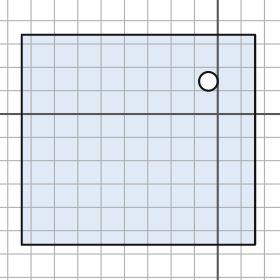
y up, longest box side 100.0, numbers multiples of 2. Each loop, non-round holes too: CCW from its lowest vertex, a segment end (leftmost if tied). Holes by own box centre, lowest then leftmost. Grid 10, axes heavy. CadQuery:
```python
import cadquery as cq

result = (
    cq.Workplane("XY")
    .moveTo(-84.0, -56.0)
    .lineTo(16.0, -56.0)
    .lineTo(16.0, 34.0)
    .lineTo(-84.0, 34.0)
    .close()
    .moveTo(-4.0, 14.0)
    .circle(4.0)
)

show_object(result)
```